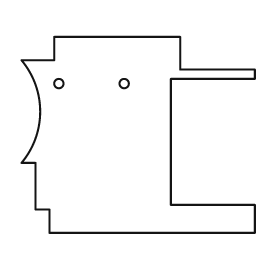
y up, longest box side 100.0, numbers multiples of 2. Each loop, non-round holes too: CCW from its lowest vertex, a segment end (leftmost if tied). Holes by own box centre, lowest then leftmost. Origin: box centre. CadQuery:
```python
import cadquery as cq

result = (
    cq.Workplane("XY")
    .moveTo(-38.0, -42.0)
    .lineTo(50.0, -42.0)
    .lineTo(50.0, -30.0)
    .lineTo(14.0, -30.0)
    .lineTo(14.0, 24.0)
    .lineTo(50.0, 24.0)
    .lineTo(50.0, 28.0)
    .lineTo(18.0, 28.0)
    .lineTo(18.0, 42.0)
    .lineTo(-36.0, 42.0)
    .lineTo(-36.0, 32.0)
    .lineTo(-50.0, 32.0)
    .threePointArc((-42.0, 10.0), (-50.0, -12.0))
    .lineTo(-44.0, -12.0)
    .lineTo(-44.0, -32.0)
    .lineTo(-38.0, -32.0)
    .close()
    .moveTo(-34.0, 22.0)
    .circle(2.0)
    .moveTo(-6.0, 22.0)
    .circle(2.0)
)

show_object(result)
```